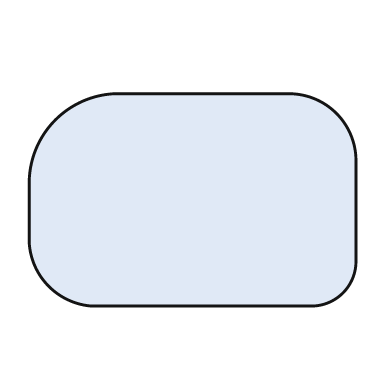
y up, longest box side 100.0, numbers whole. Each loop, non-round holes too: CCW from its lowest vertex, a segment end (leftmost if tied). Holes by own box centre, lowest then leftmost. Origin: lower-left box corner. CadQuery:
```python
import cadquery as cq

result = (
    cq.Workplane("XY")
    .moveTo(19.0, 0.0)
    .lineTo(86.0, 0.0)
    .threePointArc((96.0, 4.0), (100.0, 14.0))
    .lineTo(100.0, 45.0)
    .threePointArc((94.0, 59.0), (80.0, 65.0))
    .lineTo(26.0, 65.0)
    .threePointArc((8.0, 57.0), (0.0, 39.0))
    .lineTo(0.0, 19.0)
    .threePointArc((6.0, 6.0), (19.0, 0.0))
    .close()
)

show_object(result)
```